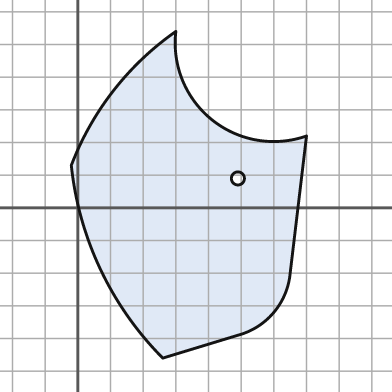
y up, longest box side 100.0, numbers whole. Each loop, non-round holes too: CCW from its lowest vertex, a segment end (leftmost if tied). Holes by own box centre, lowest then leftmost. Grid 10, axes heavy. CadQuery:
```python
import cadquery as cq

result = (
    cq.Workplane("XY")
    .moveTo(26.0, -46.0)
    .lineTo(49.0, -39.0)
    .threePointArc((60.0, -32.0), (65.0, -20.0))
    .lineTo(70.0, 22.0)
    .threePointArc((41.0, 27.0), (30.0, 54.0))
    .threePointArc((11.0, 36.0), (-2.0, 13.0))
    .threePointArc((7.0, -19.0), (26.0, -46.0))
    .close()
    .moveTo(49.0, 9.0)
    .circle(2.0)
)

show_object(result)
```